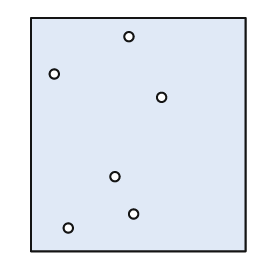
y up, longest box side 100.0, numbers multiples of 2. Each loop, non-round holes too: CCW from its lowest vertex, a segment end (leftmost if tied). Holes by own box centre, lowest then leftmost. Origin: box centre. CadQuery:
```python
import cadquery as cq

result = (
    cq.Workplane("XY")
    .moveTo(-46.0, -50.0)
    .lineTo(46.0, -50.0)
    .lineTo(46.0, 50.0)
    .lineTo(-46.0, 50.0)
    .close()
    .moveTo(-30.0, -40.0)
    .circle(2.0)
    .moveTo(-2.0, -34.0)
    .circle(2.0)
    .moveTo(-10.0, -18.0)
    .circle(2.0)
    .moveTo(10.0, 16.0)
    .circle(2.0)
    .moveTo(-36.0, 26.0)
    .circle(2.0)
    .moveTo(-4.0, 42.0)
    .circle(2.0)
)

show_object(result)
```